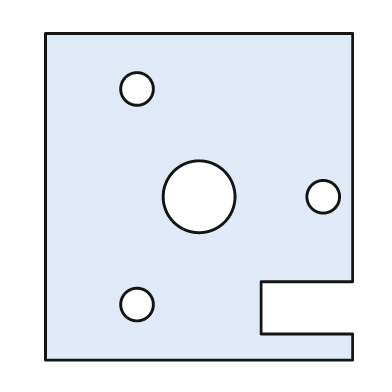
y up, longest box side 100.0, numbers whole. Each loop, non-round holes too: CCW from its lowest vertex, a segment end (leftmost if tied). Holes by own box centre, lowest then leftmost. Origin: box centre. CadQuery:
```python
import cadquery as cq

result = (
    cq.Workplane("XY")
    .moveTo(-47.0, -50.0)
    .lineTo(47.0, -50.0)
    .lineTo(47.0, -42.0)
    .lineTo(19.0, -42.0)
    .lineTo(19.0, -26.0)
    .lineTo(47.0, -26.0)
    .lineTo(47.0, 50.0)
    .lineTo(-47.0, 50.0)
    .close()
    .moveTo(-19.0, -33.0)
    .circle(5.0)
    .moveTo(0.0, 0.0)
    .circle(11.0)
    .moveTo(38.0, 0.0)
    .circle(5.0)
    .moveTo(-19.0, 33.0)
    .circle(5.0)
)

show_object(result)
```